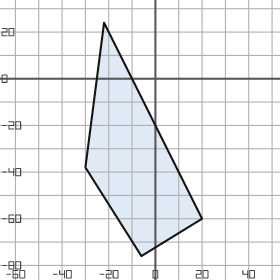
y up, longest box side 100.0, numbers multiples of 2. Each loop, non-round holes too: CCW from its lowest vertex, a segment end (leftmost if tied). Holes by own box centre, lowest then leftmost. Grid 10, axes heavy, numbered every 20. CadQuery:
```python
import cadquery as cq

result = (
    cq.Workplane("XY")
    .moveTo(-6.0, -76.0)
    .lineTo(20.0, -60.0)
    .lineTo(-22.0, 24.0)
    .lineTo(-30.0, -38.0)
    .close()
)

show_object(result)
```